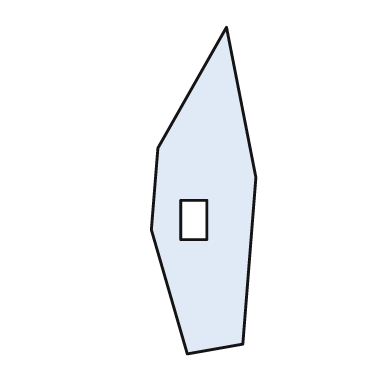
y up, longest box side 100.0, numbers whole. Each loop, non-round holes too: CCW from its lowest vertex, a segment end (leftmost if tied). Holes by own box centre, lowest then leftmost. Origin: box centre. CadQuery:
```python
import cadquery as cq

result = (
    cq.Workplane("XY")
    .moveTo(-5.0, -50.0)
    .lineTo(12.0, -47.0)
    .lineTo(16.0, 4.0)
    .lineTo(7.0, 50.0)
    .lineTo(-14.0, 13.0)
    .lineTo(-16.0, -12.0)
    .close()
    .moveTo(-7.0, -15.0)
    .lineTo(1.0, -15.0)
    .lineTo(1.0, -3.0)
    .lineTo(-7.0, -3.0)
    .close()
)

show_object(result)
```